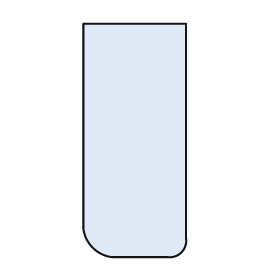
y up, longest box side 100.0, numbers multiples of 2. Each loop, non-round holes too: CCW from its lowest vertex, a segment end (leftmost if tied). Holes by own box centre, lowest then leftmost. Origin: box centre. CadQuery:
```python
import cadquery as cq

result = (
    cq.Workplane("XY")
    .moveTo(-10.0, -50.0)
    .lineTo(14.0, -50.0)
    .threePointArc((20.0, -48.0), (22.0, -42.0))
    .lineTo(22.0, 50.0)
    .lineTo(-22.0, 50.0)
    .lineTo(-22.0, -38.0)
    .threePointArc((-18.0, -46.0), (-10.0, -50.0))
    .close()
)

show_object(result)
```